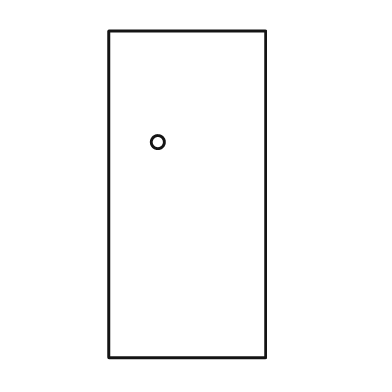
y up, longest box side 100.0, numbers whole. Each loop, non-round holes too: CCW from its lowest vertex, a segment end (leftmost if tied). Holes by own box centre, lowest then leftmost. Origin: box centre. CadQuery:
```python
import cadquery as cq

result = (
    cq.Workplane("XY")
    .moveTo(-24.0, -50.0)
    .lineTo(24.0, -50.0)
    .lineTo(24.0, 50.0)
    .lineTo(-24.0, 50.0)
    .close()
    .moveTo(-9.0, 16.0)
    .circle(2.0)
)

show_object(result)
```